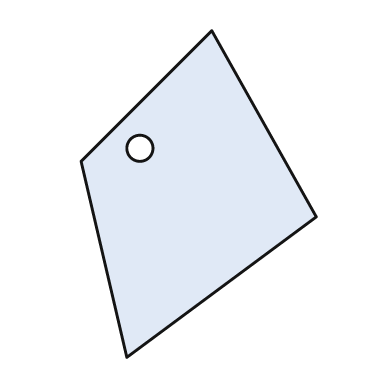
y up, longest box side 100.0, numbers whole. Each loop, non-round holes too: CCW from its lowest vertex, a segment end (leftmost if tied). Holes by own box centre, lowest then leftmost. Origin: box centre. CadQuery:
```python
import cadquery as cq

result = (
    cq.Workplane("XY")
    .moveTo(-22.0, -50.0)
    .lineTo(36.0, -7.0)
    .lineTo(4.0, 50.0)
    .lineTo(-36.0, 10.0)
    .close()
    .moveTo(-18.0, 14.0)
    .circle(4.0)
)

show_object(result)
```